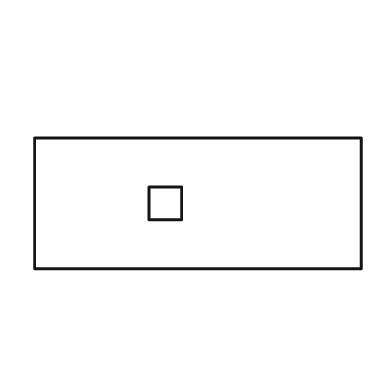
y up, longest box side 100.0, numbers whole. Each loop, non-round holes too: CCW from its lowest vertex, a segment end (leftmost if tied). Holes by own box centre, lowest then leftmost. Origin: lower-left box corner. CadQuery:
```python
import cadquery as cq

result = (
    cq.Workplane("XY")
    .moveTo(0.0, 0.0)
    .lineTo(100.0, 0.0)
    .lineTo(100.0, 40.0)
    .lineTo(0.0, 40.0)
    .close()
    .moveTo(35.0, 15.0)
    .lineTo(45.0, 15.0)
    .lineTo(45.0, 25.0)
    .lineTo(35.0, 25.0)
    .close()
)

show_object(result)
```